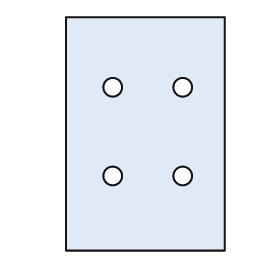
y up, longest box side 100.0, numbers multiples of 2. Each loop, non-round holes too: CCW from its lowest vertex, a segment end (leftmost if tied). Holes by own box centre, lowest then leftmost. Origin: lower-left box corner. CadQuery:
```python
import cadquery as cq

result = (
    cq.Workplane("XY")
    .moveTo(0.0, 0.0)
    .lineTo(68.0, 0.0)
    .lineTo(68.0, 100.0)
    .lineTo(0.0, 100.0)
    .close()
    .moveTo(20.0, 32.0)
    .circle(4.0)
    .moveTo(50.0, 32.0)
    .circle(4.0)
    .moveTo(20.0, 70.0)
    .circle(4.0)
    .moveTo(50.0, 70.0)
    .circle(4.0)
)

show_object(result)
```